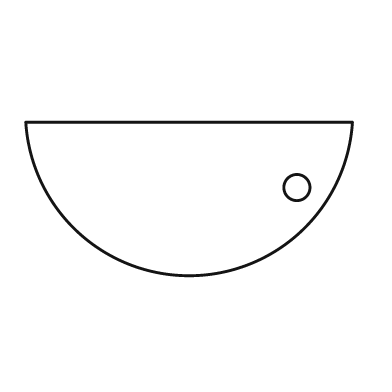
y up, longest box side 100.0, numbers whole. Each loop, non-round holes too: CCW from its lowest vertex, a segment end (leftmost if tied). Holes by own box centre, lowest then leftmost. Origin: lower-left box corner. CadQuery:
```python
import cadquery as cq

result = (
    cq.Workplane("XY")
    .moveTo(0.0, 47.0)
    .threePointArc((50.0, 0.0), (100.0, 47.0))
    .close()
    .moveTo(83.0, 27.0)
    .circle(4.0)
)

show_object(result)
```